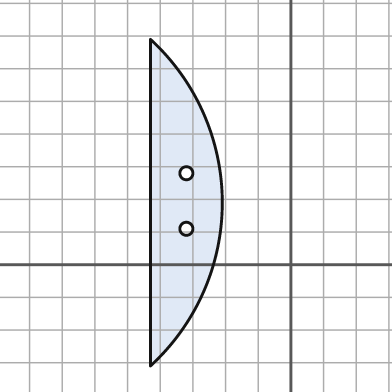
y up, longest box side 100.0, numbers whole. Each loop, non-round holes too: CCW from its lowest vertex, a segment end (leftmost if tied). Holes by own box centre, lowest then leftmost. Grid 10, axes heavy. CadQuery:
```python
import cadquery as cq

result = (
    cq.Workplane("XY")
    .moveTo(-43.0, -31.0)
    .threePointArc((-21.0, 19.0), (-43.0, 69.0))
    .close()
    .moveTo(-32.0, 11.0)
    .circle(2.0)
    .moveTo(-32.0, 28.0)
    .circle(2.0)
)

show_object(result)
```